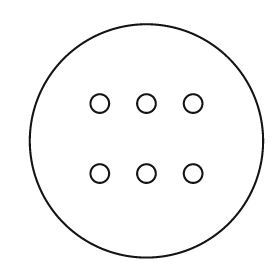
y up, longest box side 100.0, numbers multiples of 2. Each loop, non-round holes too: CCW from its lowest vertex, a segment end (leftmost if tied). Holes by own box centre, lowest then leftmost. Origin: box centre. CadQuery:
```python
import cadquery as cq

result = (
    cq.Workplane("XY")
    .moveTo(0.0, 0.0)
    .circle(50.0)
    .moveTo(-20.0, -14.0)
    .circle(4.0)
    .moveTo(0.0, -14.0)
    .circle(4.0)
    .moveTo(20.0, -14.0)
    .circle(4.0)
    .moveTo(-20.0, 16.0)
    .circle(4.0)
    .moveTo(0.0, 16.0)
    .circle(4.0)
    .moveTo(20.0, 16.0)
    .circle(4.0)
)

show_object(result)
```